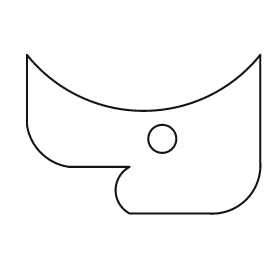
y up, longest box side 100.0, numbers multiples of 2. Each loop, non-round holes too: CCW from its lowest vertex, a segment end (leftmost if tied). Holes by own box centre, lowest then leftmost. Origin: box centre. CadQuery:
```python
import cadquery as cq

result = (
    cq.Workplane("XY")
    .moveTo(-6.0, -34.0)
    .lineTo(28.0, -34.0)
    .threePointArc((44.0, -28.0), (50.0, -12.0))
    .lineTo(50.0, 34.0)
    .threePointArc((0.0, 10.0), (-50.0, 34.0))
    .lineTo(-50.0, 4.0)
    .threePointArc((-44.0, -8.0), (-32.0, -14.0))
    .lineTo(-6.0, -14.0)
    .threePointArc((-12.0, -24.0), (-6.0, -34.0))
    .close()
    .moveTo(8.0, -2.0)
    .circle(6.0)
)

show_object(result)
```